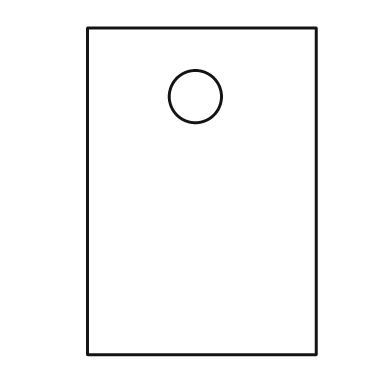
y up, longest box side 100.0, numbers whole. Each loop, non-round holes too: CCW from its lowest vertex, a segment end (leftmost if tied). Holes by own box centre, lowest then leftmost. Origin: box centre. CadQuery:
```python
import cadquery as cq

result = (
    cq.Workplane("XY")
    .moveTo(-35.0, -50.0)
    .lineTo(35.0, -50.0)
    .lineTo(35.0, 50.0)
    .lineTo(-35.0, 50.0)
    .close()
    .moveTo(-2.0, 29.0)
    .circle(8.0)
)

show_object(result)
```